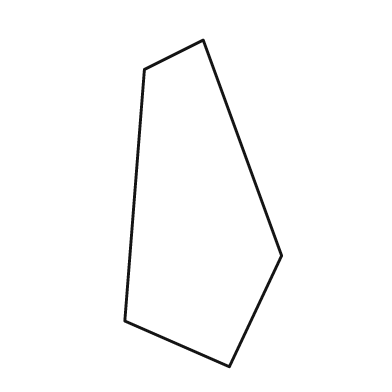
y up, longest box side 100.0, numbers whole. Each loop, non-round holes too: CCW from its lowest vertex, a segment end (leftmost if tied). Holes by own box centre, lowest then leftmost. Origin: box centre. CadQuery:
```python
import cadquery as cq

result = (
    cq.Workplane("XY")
    .moveTo(8.0, -50.0)
    .lineTo(24.0, -16.0)
    .lineTo(0.0, 50.0)
    .lineTo(-18.0, 41.0)
    .lineTo(-24.0, -36.0)
    .close()
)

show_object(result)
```